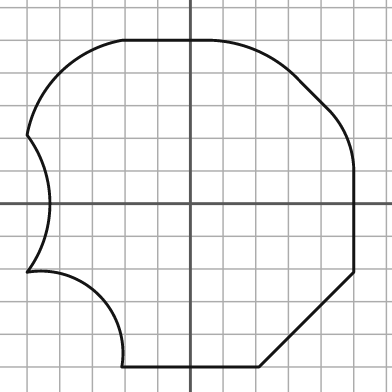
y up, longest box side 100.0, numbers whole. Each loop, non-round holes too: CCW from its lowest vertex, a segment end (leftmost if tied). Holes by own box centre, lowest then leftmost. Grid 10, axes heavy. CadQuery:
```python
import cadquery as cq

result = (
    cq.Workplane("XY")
    .moveTo(-21.0, -50.0)
    .lineTo(21.0, -50.0)
    .lineTo(50.0, -21.0)
    .lineTo(50.0, 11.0)
    .threePointArc((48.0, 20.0), (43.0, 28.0))
    .lineTo(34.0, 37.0)
    .threePointArc((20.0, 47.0), (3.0, 50.0))
    .lineTo(-21.0, 50.0)
    .threePointArc((-40.0, 40.0), (-50.0, 21.0))
    .threePointArc((-43.0, 0.0), (-50.0, -21.0))
    .threePointArc((-28.0, -28.0), (-21.0, -50.0))
    .close()
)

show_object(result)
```